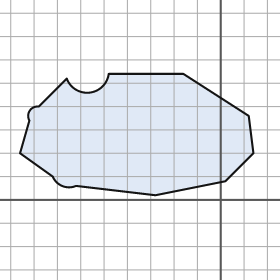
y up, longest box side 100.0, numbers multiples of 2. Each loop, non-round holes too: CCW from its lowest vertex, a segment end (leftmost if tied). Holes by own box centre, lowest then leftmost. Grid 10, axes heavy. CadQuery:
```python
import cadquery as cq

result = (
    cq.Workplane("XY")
    .moveTo(-28.0, 2.0)
    .lineTo(2.0, 8.0)
    .lineTo(14.0, 20.0)
    .lineTo(12.0, 36.0)
    .lineTo(-16.0, 54.0)
    .lineTo(-48.0, 54.0)
    .threePointArc((-56.0, 46.0), (-66.0, 52.0))
    .lineTo(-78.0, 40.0)
    .threePointArc((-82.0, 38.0), (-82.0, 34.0))
    .lineTo(-86.0, 20.0)
    .lineTo(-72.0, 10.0)
    .threePointArc((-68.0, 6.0), (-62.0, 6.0))
    .close()
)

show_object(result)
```